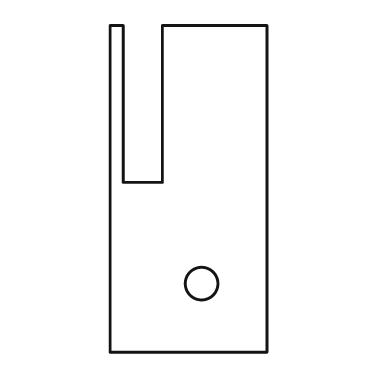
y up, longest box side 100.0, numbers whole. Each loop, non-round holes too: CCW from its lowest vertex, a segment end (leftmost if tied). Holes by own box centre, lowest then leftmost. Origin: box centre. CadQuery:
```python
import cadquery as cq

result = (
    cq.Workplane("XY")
    .moveTo(-24.0, -50.0)
    .lineTo(24.0, -50.0)
    .lineTo(24.0, 50.0)
    .lineTo(-8.0, 50.0)
    .lineTo(-8.0, 2.0)
    .lineTo(-20.0, 2.0)
    .lineTo(-20.0, 50.0)
    .lineTo(-24.0, 50.0)
    .close()
    .moveTo(4.0, -29.0)
    .circle(5.0)
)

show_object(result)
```